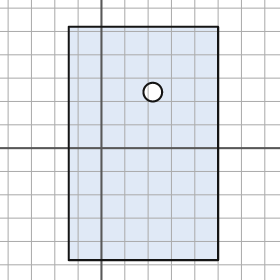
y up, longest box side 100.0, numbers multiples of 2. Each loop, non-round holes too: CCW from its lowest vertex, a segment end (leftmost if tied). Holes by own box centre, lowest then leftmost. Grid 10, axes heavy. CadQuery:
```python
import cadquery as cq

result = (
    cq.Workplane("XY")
    .moveTo(-14.0, -48.0)
    .lineTo(50.0, -48.0)
    .lineTo(50.0, 52.0)
    .lineTo(-14.0, 52.0)
    .close()
    .moveTo(22.0, 24.0)
    .circle(4.0)
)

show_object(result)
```